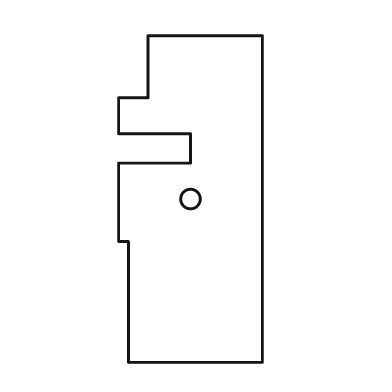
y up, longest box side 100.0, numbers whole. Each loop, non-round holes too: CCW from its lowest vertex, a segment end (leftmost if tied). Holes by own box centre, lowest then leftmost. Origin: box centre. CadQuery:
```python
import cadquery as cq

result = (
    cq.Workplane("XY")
    .moveTo(-19.0, -50.0)
    .lineTo(22.0, -50.0)
    .lineTo(22.0, 50.0)
    .lineTo(-13.0, 50.0)
    .lineTo(-13.0, 31.0)
    .lineTo(-22.0, 31.0)
    .lineTo(-22.0, 20.0)
    .lineTo(0.0, 20.0)
    .lineTo(0.0, 11.0)
    .lineTo(-22.0, 11.0)
    .lineTo(-22.0, -13.0)
    .lineTo(-19.0, -13.0)
    .close()
    .moveTo(0.0, 0.0)
    .circle(3.0)
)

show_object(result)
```